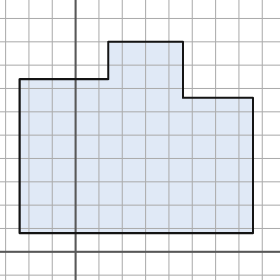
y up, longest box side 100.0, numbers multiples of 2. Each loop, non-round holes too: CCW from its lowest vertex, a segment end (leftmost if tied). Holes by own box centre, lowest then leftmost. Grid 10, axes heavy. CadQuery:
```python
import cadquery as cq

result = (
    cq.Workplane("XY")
    .moveTo(-24.0, 8.0)
    .lineTo(76.0, 8.0)
    .lineTo(76.0, 66.0)
    .lineTo(46.0, 66.0)
    .lineTo(46.0, 90.0)
    .lineTo(14.0, 90.0)
    .lineTo(14.0, 74.0)
    .lineTo(-24.0, 74.0)
    .close()
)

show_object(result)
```